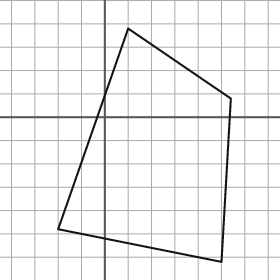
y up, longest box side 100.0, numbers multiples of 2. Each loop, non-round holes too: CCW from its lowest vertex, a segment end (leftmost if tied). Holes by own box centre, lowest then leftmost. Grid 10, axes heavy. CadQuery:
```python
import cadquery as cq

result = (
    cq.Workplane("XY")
    .moveTo(50.0, -62.0)
    .lineTo(54.0, 8.0)
    .lineTo(10.0, 38.0)
    .lineTo(-20.0, -48.0)
    .close()
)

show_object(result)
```